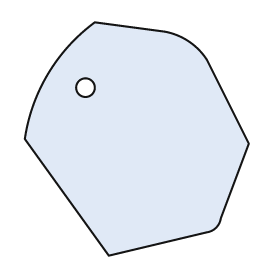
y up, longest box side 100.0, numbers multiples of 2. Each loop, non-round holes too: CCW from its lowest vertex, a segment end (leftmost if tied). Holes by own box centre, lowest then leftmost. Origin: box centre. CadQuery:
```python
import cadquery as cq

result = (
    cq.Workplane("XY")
    .moveTo(-12.0, -50.0)
    .lineTo(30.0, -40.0)
    .threePointArc((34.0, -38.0), (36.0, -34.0))
    .lineTo(48.0, -2.0)
    .lineTo(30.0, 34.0)
    .threePointArc((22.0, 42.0), (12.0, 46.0))
    .lineTo(-18.0, 50.0)
    .threePointArc((-38.0, 28.0), (-48.0, 0.0))
    .close()
    .moveTo(-22.0, 22.0)
    .circle(4.0)
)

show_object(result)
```